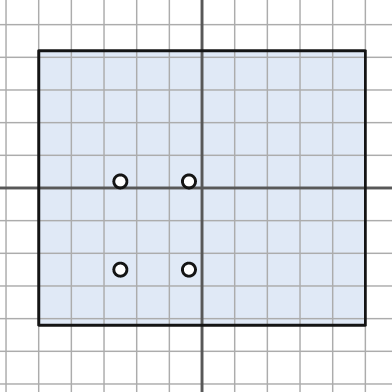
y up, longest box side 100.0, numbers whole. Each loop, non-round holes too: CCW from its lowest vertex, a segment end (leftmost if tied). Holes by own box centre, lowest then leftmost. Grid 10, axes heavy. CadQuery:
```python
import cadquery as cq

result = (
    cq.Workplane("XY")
    .moveTo(-50.0, -42.0)
    .lineTo(50.0, -42.0)
    .lineTo(50.0, 42.0)
    .lineTo(-50.0, 42.0)
    .close()
    .moveTo(-25.0, -25.0)
    .circle(2.0)
    .moveTo(-4.0, -25.0)
    .circle(2.0)
    .moveTo(-25.0, 2.0)
    .circle(2.0)
    .moveTo(-4.0, 2.0)
    .circle(2.0)
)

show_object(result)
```